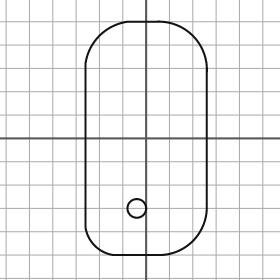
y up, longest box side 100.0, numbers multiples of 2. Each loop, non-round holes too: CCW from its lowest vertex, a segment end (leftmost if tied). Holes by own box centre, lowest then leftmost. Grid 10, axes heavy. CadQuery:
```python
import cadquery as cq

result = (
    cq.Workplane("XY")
    .moveTo(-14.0, -50.0)
    .lineTo(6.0, -50.0)
    .threePointArc((20.0, -44.0), (26.0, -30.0))
    .lineTo(26.0, 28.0)
    .threePointArc((20.0, 44.0), (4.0, 50.0))
    .lineTo(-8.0, 50.0)
    .threePointArc((-20.0, 44.0), (-26.0, 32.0))
    .lineTo(-26.0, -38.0)
    .threePointArc((-22.0, -46.0), (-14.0, -50.0))
    .close()
    .moveTo(-4.0, -30.0)
    .circle(4.0)
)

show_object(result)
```